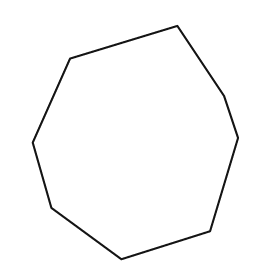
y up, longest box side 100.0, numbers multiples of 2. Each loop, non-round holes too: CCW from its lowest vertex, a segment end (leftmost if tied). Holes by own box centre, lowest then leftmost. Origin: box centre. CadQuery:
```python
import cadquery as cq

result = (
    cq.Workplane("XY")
    .moveTo(-6.0, -50.0)
    .lineTo(32.0, -38.0)
    .lineTo(44.0, 2.0)
    .lineTo(38.0, 20.0)
    .lineTo(18.0, 50.0)
    .lineTo(-28.0, 36.0)
    .lineTo(-44.0, 0.0)
    .lineTo(-36.0, -28.0)
    .close()
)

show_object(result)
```